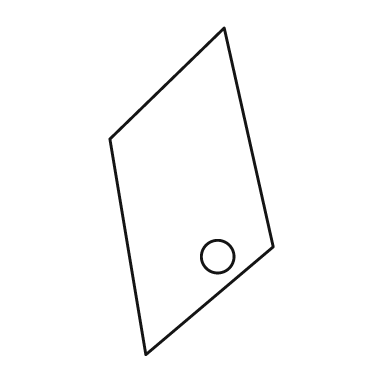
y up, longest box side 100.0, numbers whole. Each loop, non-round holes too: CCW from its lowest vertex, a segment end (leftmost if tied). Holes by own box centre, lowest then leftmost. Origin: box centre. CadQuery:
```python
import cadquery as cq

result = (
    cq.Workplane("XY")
    .moveTo(-14.0, -50.0)
    .lineTo(25.0, -17.0)
    .lineTo(10.0, 50.0)
    .lineTo(-25.0, 16.0)
    .close()
    .moveTo(8.0, -20.0)
    .circle(5.0)
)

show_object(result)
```